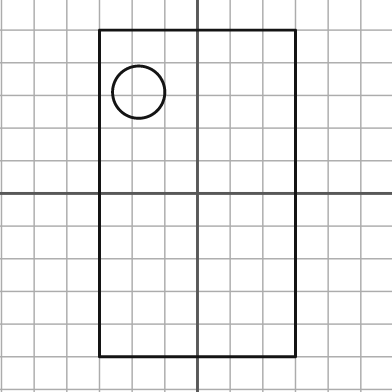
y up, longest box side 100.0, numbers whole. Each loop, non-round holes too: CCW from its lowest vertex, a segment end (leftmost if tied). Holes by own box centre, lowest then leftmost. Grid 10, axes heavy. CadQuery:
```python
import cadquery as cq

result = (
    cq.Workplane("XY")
    .moveTo(-30.0, -50.0)
    .lineTo(30.0, -50.0)
    .lineTo(30.0, 50.0)
    .lineTo(-30.0, 50.0)
    .close()
    .moveTo(-18.0, 31.0)
    .circle(8.0)
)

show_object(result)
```